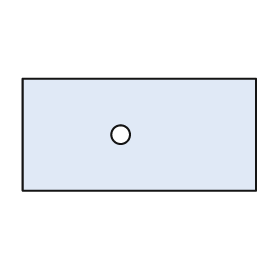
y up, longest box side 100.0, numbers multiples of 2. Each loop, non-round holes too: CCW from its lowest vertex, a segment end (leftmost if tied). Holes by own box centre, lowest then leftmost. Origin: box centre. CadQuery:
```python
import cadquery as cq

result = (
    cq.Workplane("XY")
    .moveTo(-50.0, -24.0)
    .lineTo(50.0, -24.0)
    .lineTo(50.0, 24.0)
    .lineTo(-50.0, 24.0)
    .close()
    .moveTo(-8.0, 0.0)
    .circle(4.0)
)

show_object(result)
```